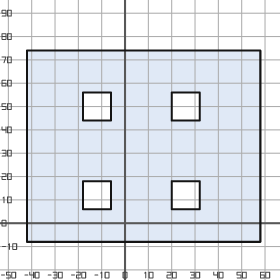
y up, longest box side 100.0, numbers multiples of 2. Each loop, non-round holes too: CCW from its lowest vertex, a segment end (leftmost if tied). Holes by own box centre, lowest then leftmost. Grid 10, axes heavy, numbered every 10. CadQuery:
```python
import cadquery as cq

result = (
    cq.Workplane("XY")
    .moveTo(-42.0, -8.0)
    .lineTo(58.0, -8.0)
    .lineTo(58.0, 74.0)
    .lineTo(-42.0, 74.0)
    .close()
    .moveTo(-18.0, 6.0)
    .lineTo(-6.0, 6.0)
    .lineTo(-6.0, 18.0)
    .lineTo(-18.0, 18.0)
    .close()
    .moveTo(20.0, 6.0)
    .lineTo(32.0, 6.0)
    .lineTo(32.0, 18.0)
    .lineTo(20.0, 18.0)
    .close()
    .moveTo(-18.0, 44.0)
    .lineTo(-6.0, 44.0)
    .lineTo(-6.0, 56.0)
    .lineTo(-18.0, 56.0)
    .close()
    .moveTo(20.0, 44.0)
    .lineTo(32.0, 44.0)
    .lineTo(32.0, 56.0)
    .lineTo(20.0, 56.0)
    .close()
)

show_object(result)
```